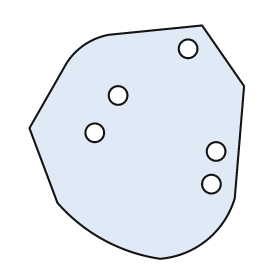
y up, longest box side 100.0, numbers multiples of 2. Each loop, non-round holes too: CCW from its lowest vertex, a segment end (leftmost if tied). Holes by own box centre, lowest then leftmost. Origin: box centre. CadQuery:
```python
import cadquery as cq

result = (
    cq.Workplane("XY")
    .moveTo(10.0, -50.0)
    .threePointArc((30.0, -42.0), (42.0, -24.0))
    .lineTo(46.0, 24.0)
    .lineTo(28.0, 50.0)
    .lineTo(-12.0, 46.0)
    .threePointArc((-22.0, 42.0), (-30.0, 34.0))
    .lineTo(-46.0, 6.0)
    .lineTo(-34.0, -26.0)
    .threePointArc((-14.0, -42.0), (10.0, -50.0))
    .close()
    .moveTo(32.0, -18.0)
    .circle(4.0)
    .moveTo(34.0, -4.0)
    .circle(4.0)
    .moveTo(-18.0, 4.0)
    .circle(4.0)
    .moveTo(-8.0, 20.0)
    .circle(4.0)
    .moveTo(22.0, 40.0)
    .circle(4.0)
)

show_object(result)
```